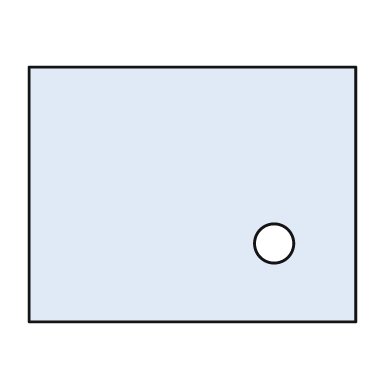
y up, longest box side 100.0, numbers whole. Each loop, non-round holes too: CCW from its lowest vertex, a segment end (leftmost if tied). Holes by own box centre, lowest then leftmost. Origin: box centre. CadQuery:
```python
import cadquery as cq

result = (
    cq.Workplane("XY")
    .moveTo(-50.0, -39.0)
    .lineTo(50.0, -39.0)
    .lineTo(50.0, 39.0)
    .lineTo(-50.0, 39.0)
    .close()
    .moveTo(25.0, -15.0)
    .circle(6.0)
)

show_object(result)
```